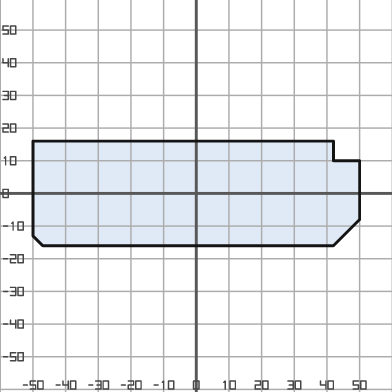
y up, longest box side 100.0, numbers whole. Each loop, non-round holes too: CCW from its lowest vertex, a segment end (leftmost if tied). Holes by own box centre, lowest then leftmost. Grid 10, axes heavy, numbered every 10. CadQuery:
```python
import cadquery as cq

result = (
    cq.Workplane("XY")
    .moveTo(-47.0, -16.0)
    .lineTo(42.0, -16.0)
    .lineTo(50.0, -8.0)
    .lineTo(50.0, 10.0)
    .lineTo(42.0, 10.0)
    .lineTo(42.0, 16.0)
    .lineTo(-50.0, 16.0)
    .lineTo(-50.0, -13.0)
    .close()
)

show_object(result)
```